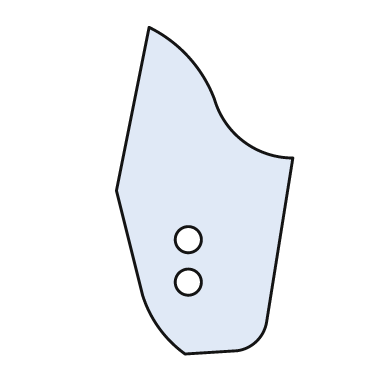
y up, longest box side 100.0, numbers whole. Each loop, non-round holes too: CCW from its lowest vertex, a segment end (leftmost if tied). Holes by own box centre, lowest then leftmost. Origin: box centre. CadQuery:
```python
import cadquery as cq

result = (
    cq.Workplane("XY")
    .moveTo(-6.0, -50.0)
    .lineTo(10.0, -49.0)
    .threePointArc((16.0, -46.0), (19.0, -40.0))
    .lineTo(27.0, 10.0)
    .threePointArc((12.0, 15.0), (3.0, 28.0))
    .threePointArc((-5.0, 41.0), (-17.0, 50.0))
    .lineTo(-27.0, 0.0)
    .lineTo(-19.0, -32.0)
    .threePointArc((-14.0, -42.0), (-6.0, -50.0))
    .close()
    .moveTo(-5.0, -28.0)
    .circle(4.0)
    .moveTo(-5.0, -15.0)
    .circle(4.0)
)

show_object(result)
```